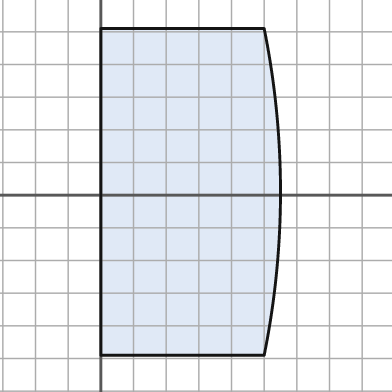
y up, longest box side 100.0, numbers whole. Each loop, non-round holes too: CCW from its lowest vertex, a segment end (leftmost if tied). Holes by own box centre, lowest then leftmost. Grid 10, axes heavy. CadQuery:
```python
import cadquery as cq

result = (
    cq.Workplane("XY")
    .moveTo(0.0, -49.0)
    .lineTo(50.0, -49.0)
    .threePointArc((55.0, 1.0), (50.0, 51.0))
    .lineTo(0.0, 51.0)
    .close()
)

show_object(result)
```